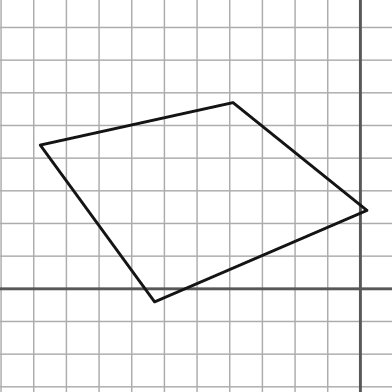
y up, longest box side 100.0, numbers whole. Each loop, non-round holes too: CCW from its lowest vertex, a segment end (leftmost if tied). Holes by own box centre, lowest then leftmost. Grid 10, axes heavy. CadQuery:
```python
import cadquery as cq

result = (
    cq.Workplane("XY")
    .moveTo(-63.0, -4.0)
    .lineTo(2.0, 24.0)
    .lineTo(-39.0, 57.0)
    .lineTo(-98.0, 44.0)
    .close()
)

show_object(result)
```